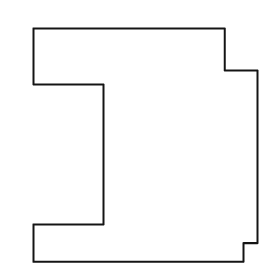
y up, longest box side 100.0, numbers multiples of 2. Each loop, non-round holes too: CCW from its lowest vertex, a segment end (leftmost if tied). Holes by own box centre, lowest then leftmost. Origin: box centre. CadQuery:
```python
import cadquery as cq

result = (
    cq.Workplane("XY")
    .moveTo(-48.0, -50.0)
    .lineTo(42.0, -50.0)
    .lineTo(42.0, -42.0)
    .lineTo(48.0, -42.0)
    .lineTo(48.0, 32.0)
    .lineTo(34.0, 32.0)
    .lineTo(34.0, 50.0)
    .lineTo(-48.0, 50.0)
    .lineTo(-48.0, 26.0)
    .lineTo(-18.0, 26.0)
    .lineTo(-18.0, -34.0)
    .lineTo(-48.0, -34.0)
    .close()
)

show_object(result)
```